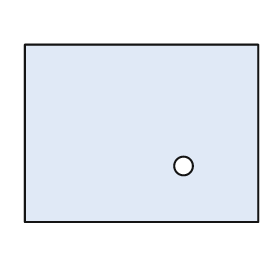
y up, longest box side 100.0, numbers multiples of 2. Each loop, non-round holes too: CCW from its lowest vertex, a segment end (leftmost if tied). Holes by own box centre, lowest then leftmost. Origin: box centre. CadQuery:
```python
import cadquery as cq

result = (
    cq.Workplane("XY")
    .moveTo(-50.0, -38.0)
    .lineTo(50.0, -38.0)
    .lineTo(50.0, 38.0)
    .lineTo(-50.0, 38.0)
    .close()
    .moveTo(18.0, -14.0)
    .circle(4.0)
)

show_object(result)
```